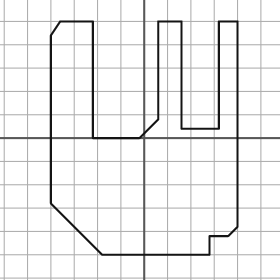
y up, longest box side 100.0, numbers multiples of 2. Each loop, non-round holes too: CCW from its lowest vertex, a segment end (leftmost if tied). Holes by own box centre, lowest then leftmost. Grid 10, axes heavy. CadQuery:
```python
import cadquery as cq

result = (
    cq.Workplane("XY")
    .moveTo(-18.0, -50.0)
    .lineTo(28.0, -50.0)
    .lineTo(28.0, -42.0)
    .lineTo(36.0, -42.0)
    .lineTo(40.0, -38.0)
    .lineTo(40.0, 50.0)
    .lineTo(32.0, 50.0)
    .lineTo(32.0, 4.0)
    .lineTo(16.0, 4.0)
    .lineTo(16.0, 50.0)
    .lineTo(6.0, 50.0)
    .lineTo(6.0, 8.0)
    .lineTo(-2.0, 0.0)
    .lineTo(-22.0, 0.0)
    .lineTo(-22.0, 50.0)
    .lineTo(-36.0, 50.0)
    .lineTo(-40.0, 44.0)
    .lineTo(-40.0, -28.0)
    .close()
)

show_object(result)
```